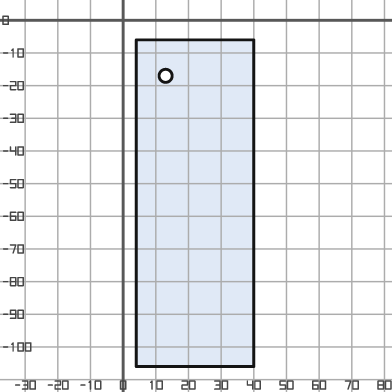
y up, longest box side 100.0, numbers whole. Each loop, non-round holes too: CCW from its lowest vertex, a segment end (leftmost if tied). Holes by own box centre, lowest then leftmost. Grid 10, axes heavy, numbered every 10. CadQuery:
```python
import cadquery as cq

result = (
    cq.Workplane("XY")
    .moveTo(4.0, -106.0)
    .lineTo(40.0, -106.0)
    .lineTo(40.0, -6.0)
    .lineTo(4.0, -6.0)
    .close()
    .moveTo(13.0, -17.0)
    .circle(2.0)
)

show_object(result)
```